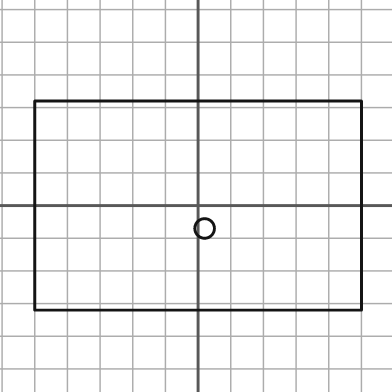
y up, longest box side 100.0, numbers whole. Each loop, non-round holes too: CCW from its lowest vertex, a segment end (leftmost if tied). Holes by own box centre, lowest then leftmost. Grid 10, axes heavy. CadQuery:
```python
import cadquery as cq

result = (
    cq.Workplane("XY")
    .moveTo(-50.0, -32.0)
    .lineTo(50.0, -32.0)
    .lineTo(50.0, 32.0)
    .lineTo(-50.0, 32.0)
    .close()
    .moveTo(2.0, -7.0)
    .circle(3.0)
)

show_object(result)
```